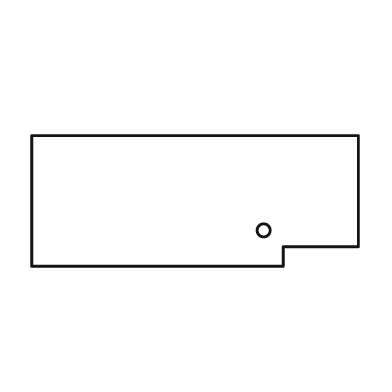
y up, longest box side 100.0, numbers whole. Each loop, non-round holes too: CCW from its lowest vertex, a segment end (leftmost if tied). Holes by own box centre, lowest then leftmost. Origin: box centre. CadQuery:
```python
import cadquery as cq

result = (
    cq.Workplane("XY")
    .moveTo(-50.0, -20.0)
    .lineTo(27.0, -20.0)
    .lineTo(27.0, -14.0)
    .lineTo(50.0, -14.0)
    .lineTo(50.0, 20.0)
    .lineTo(-50.0, 20.0)
    .close()
    .moveTo(21.0, -9.0)
    .circle(2.0)
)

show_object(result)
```